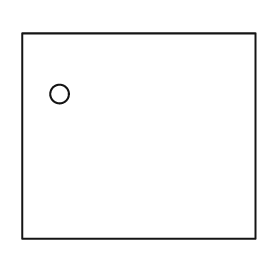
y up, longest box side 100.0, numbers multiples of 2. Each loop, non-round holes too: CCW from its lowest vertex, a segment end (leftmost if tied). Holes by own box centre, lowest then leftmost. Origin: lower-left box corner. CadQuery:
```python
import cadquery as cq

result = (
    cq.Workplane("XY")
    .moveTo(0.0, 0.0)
    .lineTo(100.0, 0.0)
    .lineTo(100.0, 88.0)
    .lineTo(0.0, 88.0)
    .close()
    .moveTo(16.0, 62.0)
    .circle(4.0)
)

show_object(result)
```